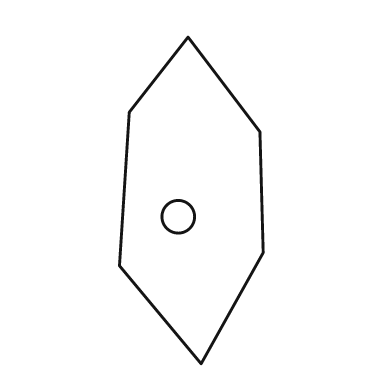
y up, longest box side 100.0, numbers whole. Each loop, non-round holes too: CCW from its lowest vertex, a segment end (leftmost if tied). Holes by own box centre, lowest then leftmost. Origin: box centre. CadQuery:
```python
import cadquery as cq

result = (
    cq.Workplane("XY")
    .moveTo(3.0, -50.0)
    .lineTo(22.0, -16.0)
    .lineTo(21.0, 21.0)
    .lineTo(-1.0, 50.0)
    .lineTo(-19.0, 27.0)
    .lineTo(-22.0, -20.0)
    .close()
    .moveTo(-4.0, -5.0)
    .circle(5.0)
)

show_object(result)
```